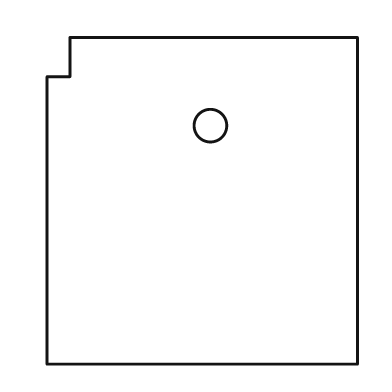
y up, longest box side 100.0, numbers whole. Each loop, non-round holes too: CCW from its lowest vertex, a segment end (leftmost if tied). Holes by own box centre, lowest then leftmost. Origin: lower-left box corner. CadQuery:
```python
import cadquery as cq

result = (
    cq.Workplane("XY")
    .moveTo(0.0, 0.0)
    .lineTo(95.0, 0.0)
    .lineTo(95.0, 100.0)
    .lineTo(7.0, 100.0)
    .lineTo(7.0, 88.0)
    .lineTo(0.0, 88.0)
    .close()
    .moveTo(50.0, 73.0)
    .circle(5.0)
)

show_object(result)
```